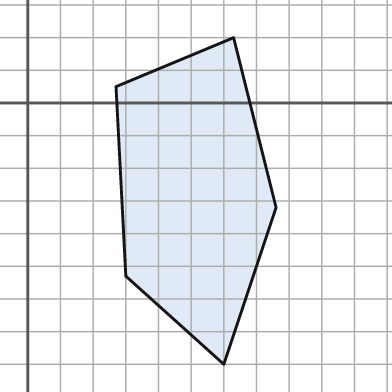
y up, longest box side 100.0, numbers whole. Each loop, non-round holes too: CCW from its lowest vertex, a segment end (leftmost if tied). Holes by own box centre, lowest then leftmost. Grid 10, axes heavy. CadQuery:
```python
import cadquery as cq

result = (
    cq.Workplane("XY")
    .moveTo(60.0, -80.0)
    .lineTo(76.0, -32.0)
    .lineTo(63.0, 20.0)
    .lineTo(27.0, 5.0)
    .lineTo(30.0, -53.0)
    .close()
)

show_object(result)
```